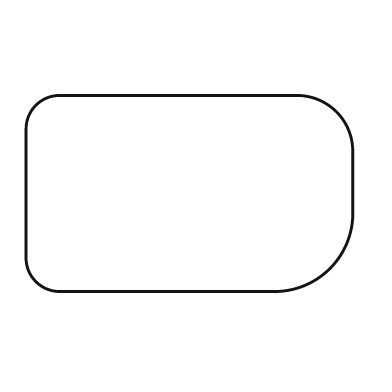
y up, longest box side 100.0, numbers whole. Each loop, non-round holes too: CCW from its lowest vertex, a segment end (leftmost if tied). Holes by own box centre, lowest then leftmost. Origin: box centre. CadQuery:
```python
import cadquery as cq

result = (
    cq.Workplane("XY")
    .moveTo(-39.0, -30.0)
    .lineTo(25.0, -30.0)
    .threePointArc((43.0, -23.0), (50.0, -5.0))
    .lineTo(50.0, 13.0)
    .threePointArc((45.0, 25.0), (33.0, 30.0))
    .lineTo(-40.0, 30.0)
    .threePointArc((-47.0, 27.0), (-50.0, 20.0))
    .lineTo(-50.0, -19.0)
    .threePointArc((-47.0, -27.0), (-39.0, -30.0))
    .close()
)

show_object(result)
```